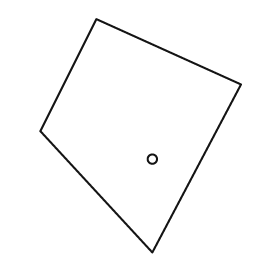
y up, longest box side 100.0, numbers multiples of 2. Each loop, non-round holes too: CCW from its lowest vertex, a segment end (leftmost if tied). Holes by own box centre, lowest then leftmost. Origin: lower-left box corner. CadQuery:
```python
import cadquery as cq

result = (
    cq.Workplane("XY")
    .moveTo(48.0, 0.0)
    .lineTo(86.0, 72.0)
    .lineTo(24.0, 100.0)
    .lineTo(0.0, 52.0)
    .close()
    .moveTo(48.0, 40.0)
    .circle(2.0)
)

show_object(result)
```